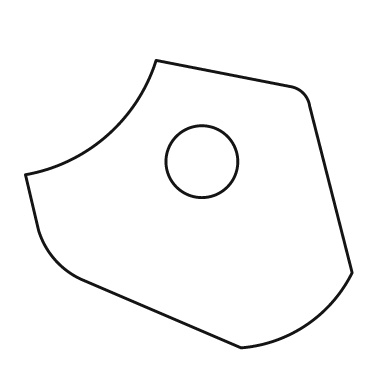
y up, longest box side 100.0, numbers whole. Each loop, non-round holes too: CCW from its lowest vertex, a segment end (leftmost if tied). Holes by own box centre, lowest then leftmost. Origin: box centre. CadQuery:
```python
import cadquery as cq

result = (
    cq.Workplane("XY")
    .moveTo(16.0, -44.0)
    .threePointArc((36.0, -37.0), (50.0, -21.0))
    .lineTo(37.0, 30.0)
    .threePointArc((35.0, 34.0), (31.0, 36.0))
    .lineTo(-10.0, 44.0)
    .threePointArc((-25.0, 21.0), (-50.0, 9.0))
    .lineTo(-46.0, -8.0)
    .threePointArc((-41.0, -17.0), (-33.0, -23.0))
    .close()
    .moveTo(4.0, 13.0)
    .circle(11.0)
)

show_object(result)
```